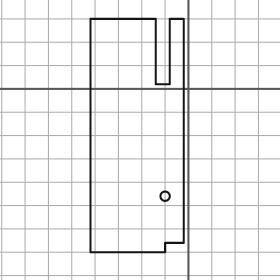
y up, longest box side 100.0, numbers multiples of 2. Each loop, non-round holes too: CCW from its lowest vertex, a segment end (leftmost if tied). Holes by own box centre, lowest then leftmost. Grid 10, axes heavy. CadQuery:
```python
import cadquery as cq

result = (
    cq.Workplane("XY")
    .moveTo(-42.0, -70.0)
    .lineTo(-10.0, -70.0)
    .lineTo(-10.0, -66.0)
    .lineTo(-2.0, -66.0)
    .lineTo(-2.0, 30.0)
    .lineTo(-8.0, 30.0)
    .lineTo(-8.0, 2.0)
    .lineTo(-14.0, 2.0)
    .lineTo(-14.0, 30.0)
    .lineTo(-42.0, 30.0)
    .close()
    .moveTo(-10.0, -46.0)
    .circle(2.0)
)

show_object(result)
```